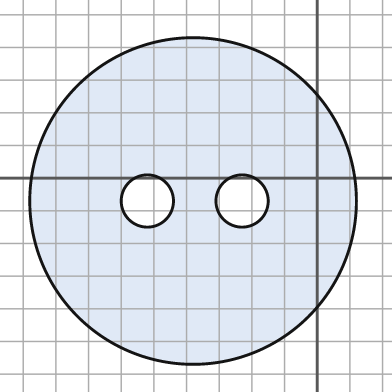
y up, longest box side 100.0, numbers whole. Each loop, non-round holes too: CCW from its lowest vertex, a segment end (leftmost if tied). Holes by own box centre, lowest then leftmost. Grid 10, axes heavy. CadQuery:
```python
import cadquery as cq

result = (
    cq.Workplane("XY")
    .moveTo(-38.0, -7.0)
    .circle(50.0)
    .moveTo(-52.0, -7.0)
    .circle(8.0)
    .moveTo(-23.0, -7.0)
    .circle(8.0)
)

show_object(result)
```